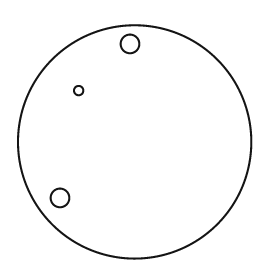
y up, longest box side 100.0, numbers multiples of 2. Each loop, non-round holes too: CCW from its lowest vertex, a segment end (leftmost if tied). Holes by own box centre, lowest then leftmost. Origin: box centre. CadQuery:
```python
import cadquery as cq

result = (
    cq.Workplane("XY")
    .moveTo(0.0, 0.0)
    .circle(50.0)
    .moveTo(-32.0, -24.0)
    .circle(4.0)
    .moveTo(-24.0, 22.0)
    .circle(2.0)
    .moveTo(-2.0, 42.0)
    .circle(4.0)
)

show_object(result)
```